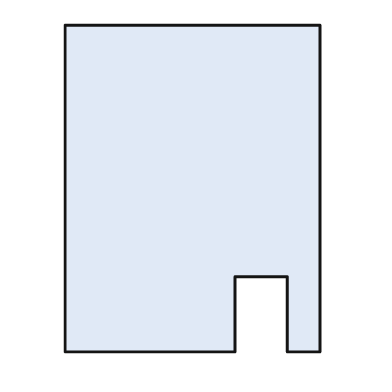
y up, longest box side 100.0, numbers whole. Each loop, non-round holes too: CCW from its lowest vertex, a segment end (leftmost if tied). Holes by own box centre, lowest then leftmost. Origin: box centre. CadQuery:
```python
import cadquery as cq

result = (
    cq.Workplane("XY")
    .moveTo(-39.0, -50.0)
    .lineTo(13.0, -50.0)
    .lineTo(13.0, -27.0)
    .lineTo(29.0, -27.0)
    .lineTo(29.0, -50.0)
    .lineTo(39.0, -50.0)
    .lineTo(39.0, 50.0)
    .lineTo(-39.0, 50.0)
    .close()
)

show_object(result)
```